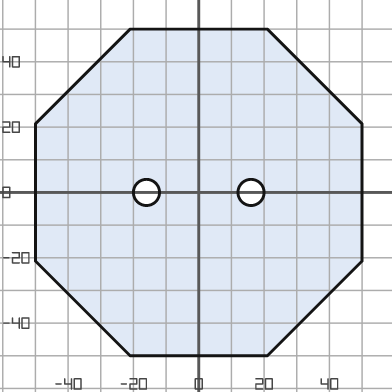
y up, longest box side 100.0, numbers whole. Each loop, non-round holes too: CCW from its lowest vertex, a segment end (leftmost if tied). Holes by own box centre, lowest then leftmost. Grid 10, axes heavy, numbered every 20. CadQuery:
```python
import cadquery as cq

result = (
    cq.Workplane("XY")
    .moveTo(-21.0, -50.0)
    .lineTo(21.0, -50.0)
    .lineTo(50.0, -21.0)
    .lineTo(50.0, 21.0)
    .lineTo(21.0, 50.0)
    .lineTo(-21.0, 50.0)
    .lineTo(-50.0, 21.0)
    .lineTo(-50.0, -21.0)
    .close()
    .moveTo(-16.0, 0.0)
    .circle(4.0)
    .moveTo(16.0, 0.0)
    .circle(4.0)
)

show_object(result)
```